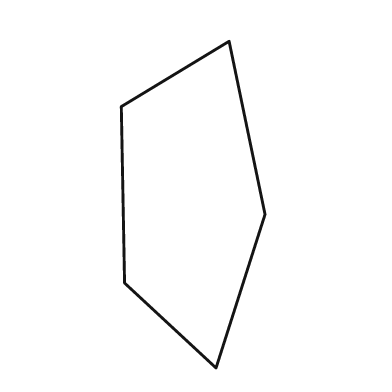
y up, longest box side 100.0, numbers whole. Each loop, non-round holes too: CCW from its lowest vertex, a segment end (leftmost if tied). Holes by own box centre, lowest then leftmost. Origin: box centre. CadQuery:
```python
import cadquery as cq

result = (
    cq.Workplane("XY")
    .moveTo(7.0, -50.0)
    .lineTo(22.0, -3.0)
    .lineTo(11.0, 50.0)
    .lineTo(-22.0, 30.0)
    .lineTo(-21.0, -24.0)
    .close()
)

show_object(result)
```